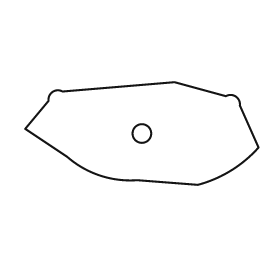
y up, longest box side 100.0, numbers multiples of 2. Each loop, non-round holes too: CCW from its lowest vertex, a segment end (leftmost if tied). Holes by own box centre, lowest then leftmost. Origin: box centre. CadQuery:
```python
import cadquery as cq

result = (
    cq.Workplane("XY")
    .moveTo(24.0, -22.0)
    .threePointArc((38.0, -16.0), (50.0, -6.0))
    .lineTo(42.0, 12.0)
    .threePointArc((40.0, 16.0), (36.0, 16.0))
    .lineTo(14.0, 22.0)
    .lineTo(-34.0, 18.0)
    .threePointArc((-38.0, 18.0), (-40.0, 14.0))
    .lineTo(-50.0, 2.0)
    .lineTo(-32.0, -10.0)
    .threePointArc((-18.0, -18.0), (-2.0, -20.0))
    .close()
    .moveTo(0.0, 0.0)
    .circle(4.0)
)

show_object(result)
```